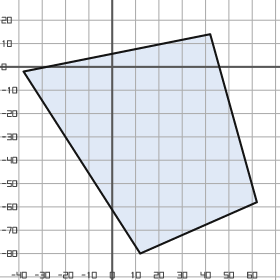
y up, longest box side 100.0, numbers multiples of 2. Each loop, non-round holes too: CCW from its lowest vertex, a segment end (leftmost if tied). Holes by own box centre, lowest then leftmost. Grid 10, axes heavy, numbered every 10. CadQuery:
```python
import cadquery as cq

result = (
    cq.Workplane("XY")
    .moveTo(12.0, -80.0)
    .lineTo(62.0, -58.0)
    .lineTo(42.0, 14.0)
    .lineTo(-38.0, -2.0)
    .close()
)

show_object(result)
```